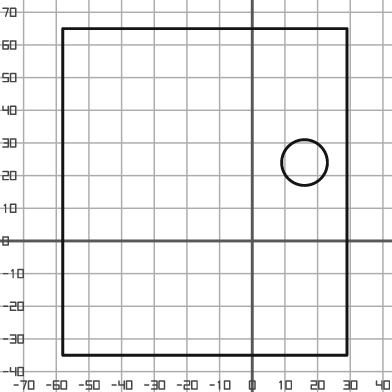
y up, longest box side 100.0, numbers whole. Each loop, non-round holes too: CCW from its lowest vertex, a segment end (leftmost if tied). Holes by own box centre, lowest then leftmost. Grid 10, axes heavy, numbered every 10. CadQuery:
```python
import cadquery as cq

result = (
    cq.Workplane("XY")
    .moveTo(-58.0, -35.0)
    .lineTo(29.0, -35.0)
    .lineTo(29.0, 65.0)
    .lineTo(-58.0, 65.0)
    .close()
    .moveTo(16.0, 24.0)
    .circle(7.0)
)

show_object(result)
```